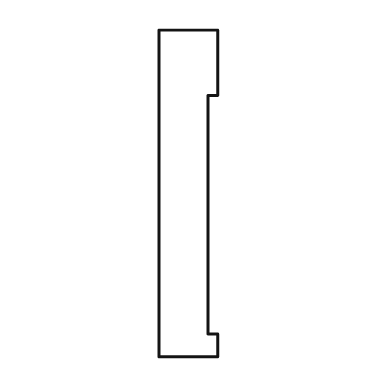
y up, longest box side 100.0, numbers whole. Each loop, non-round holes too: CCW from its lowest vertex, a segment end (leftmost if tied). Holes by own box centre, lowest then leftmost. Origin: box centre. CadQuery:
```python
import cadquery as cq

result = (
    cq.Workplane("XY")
    .moveTo(-9.0, -50.0)
    .lineTo(9.0, -50.0)
    .lineTo(9.0, -43.0)
    .lineTo(6.0, -43.0)
    .lineTo(6.0, 30.0)
    .lineTo(9.0, 30.0)
    .lineTo(9.0, 50.0)
    .lineTo(-9.0, 50.0)
    .close()
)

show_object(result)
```